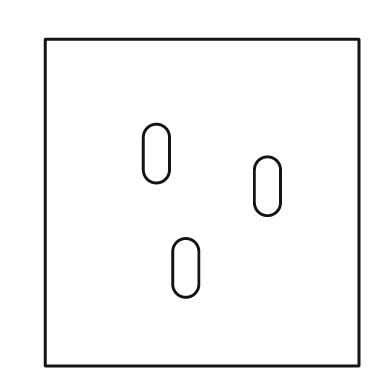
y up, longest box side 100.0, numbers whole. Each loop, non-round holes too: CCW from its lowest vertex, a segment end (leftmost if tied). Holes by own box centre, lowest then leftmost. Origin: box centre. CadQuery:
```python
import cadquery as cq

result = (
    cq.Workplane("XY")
    .moveTo(-48.0, -50.0)
    .lineTo(48.0, -50.0)
    .lineTo(48.0, 50.0)
    .lineTo(-48.0, 50.0)
    .close()
    .moveTo(-9.0, -25.0)
    .threePointArc((-5.0, -29.0), (-1.0, -25.0))
    .lineTo(-1.0, -15.0)
    .threePointArc((-5.0, -11.0), (-9.0, -15.0))
    .close()
    .moveTo(16.0, 0.0)
    .threePointArc((20.0, -4.0), (24.0, 0.0))
    .lineTo(24.0, 10.0)
    .threePointArc((20.0, 14.0), (16.0, 10.0))
    .close()
    .moveTo(-18.0, 10.0)
    .threePointArc((-14.0, 6.0), (-10.0, 10.0))
    .lineTo(-10.0, 20.0)
    .threePointArc((-14.0, 24.0), (-18.0, 20.0))
    .close()
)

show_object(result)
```